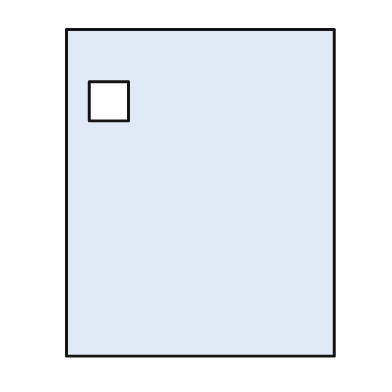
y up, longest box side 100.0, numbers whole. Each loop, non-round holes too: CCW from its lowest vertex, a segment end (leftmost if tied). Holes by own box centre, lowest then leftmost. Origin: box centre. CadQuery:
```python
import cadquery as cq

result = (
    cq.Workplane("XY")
    .moveTo(-41.0, -50.0)
    .lineTo(41.0, -50.0)
    .lineTo(41.0, 50.0)
    .lineTo(-41.0, 50.0)
    .close()
    .moveTo(-34.0, 22.0)
    .lineTo(-22.0, 22.0)
    .lineTo(-22.0, 34.0)
    .lineTo(-34.0, 34.0)
    .close()
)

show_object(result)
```